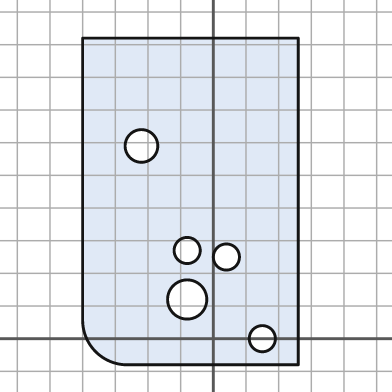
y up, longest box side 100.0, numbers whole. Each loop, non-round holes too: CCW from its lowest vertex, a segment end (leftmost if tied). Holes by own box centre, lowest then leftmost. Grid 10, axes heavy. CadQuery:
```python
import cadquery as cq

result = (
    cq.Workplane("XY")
    .moveTo(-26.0, -8.0)
    .lineTo(26.0, -8.0)
    .lineTo(26.0, 92.0)
    .lineTo(-40.0, 92.0)
    .lineTo(-40.0, 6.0)
    .threePointArc((-36.0, -4.0), (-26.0, -8.0))
    .close()
    .moveTo(15.0, 0.0)
    .circle(4.0)
    .moveTo(-8.0, 12.0)
    .circle(6.0)
    .moveTo(4.0, 25.0)
    .circle(4.0)
    .moveTo(-8.0, 27.0)
    .circle(4.0)
    .moveTo(-22.0, 59.0)
    .circle(5.0)
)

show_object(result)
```